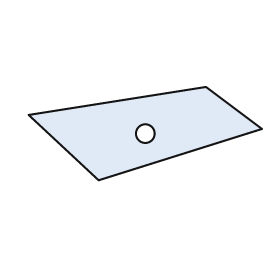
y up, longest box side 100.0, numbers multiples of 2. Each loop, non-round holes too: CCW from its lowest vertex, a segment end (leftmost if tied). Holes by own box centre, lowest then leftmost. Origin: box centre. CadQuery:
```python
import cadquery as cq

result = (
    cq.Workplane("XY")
    .moveTo(-20.0, -20.0)
    .lineTo(50.0, 2.0)
    .lineTo(26.0, 20.0)
    .lineTo(-50.0, 8.0)
    .close()
    .moveTo(0.0, 0.0)
    .circle(4.0)
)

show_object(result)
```